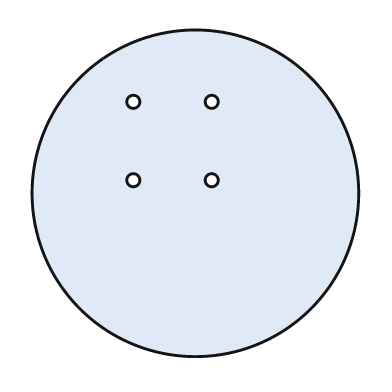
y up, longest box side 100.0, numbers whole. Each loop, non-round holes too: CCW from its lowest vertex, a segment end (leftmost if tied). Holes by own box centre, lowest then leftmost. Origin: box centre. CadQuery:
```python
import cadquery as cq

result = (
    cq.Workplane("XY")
    .moveTo(0.0, 0.0)
    .circle(50.0)
    .moveTo(-19.0, 4.0)
    .circle(2.0)
    .moveTo(5.0, 4.0)
    .circle(2.0)
    .moveTo(-19.0, 28.0)
    .circle(2.0)
    .moveTo(5.0, 28.0)
    .circle(2.0)
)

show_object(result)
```